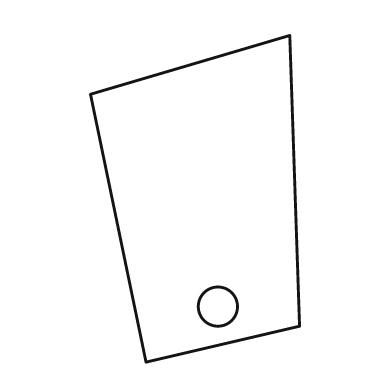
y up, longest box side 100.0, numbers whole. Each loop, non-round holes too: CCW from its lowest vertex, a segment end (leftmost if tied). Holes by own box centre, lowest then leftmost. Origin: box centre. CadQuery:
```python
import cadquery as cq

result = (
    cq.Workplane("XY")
    .moveTo(-15.0, -50.0)
    .lineTo(32.0, -39.0)
    .lineTo(29.0, 50.0)
    .lineTo(-32.0, 32.0)
    .close()
    .moveTo(7.0, -33.0)
    .circle(6.0)
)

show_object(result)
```